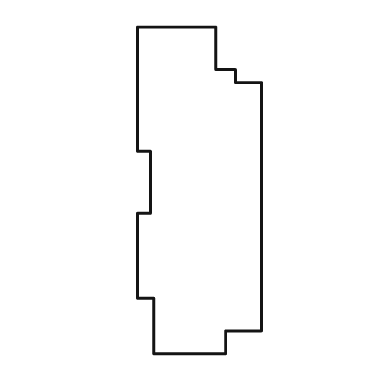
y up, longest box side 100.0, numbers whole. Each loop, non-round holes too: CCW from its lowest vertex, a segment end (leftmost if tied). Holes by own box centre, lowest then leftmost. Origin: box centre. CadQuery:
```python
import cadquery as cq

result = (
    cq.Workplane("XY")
    .moveTo(-14.0, -50.0)
    .lineTo(8.0, -50.0)
    .lineTo(8.0, -43.0)
    .lineTo(19.0, -43.0)
    .lineTo(19.0, 33.0)
    .lineTo(11.0, 33.0)
    .lineTo(11.0, 37.0)
    .lineTo(5.0, 37.0)
    .lineTo(5.0, 50.0)
    .lineTo(-19.0, 50.0)
    .lineTo(-19.0, 12.0)
    .lineTo(-15.0, 12.0)
    .lineTo(-15.0, -7.0)
    .lineTo(-19.0, -7.0)
    .lineTo(-19.0, -33.0)
    .lineTo(-14.0, -33.0)
    .close()
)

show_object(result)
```